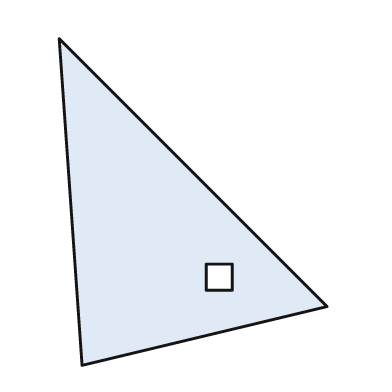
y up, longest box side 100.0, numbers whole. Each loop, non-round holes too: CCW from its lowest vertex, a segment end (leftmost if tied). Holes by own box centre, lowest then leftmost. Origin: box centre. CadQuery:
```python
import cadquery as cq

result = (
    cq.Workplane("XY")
    .moveTo(-34.0, -50.0)
    .lineTo(41.0, -32.0)
    .lineTo(-41.0, 50.0)
    .close()
    .moveTo(4.0, -27.0)
    .lineTo(12.0, -27.0)
    .lineTo(12.0, -19.0)
    .lineTo(4.0, -19.0)
    .close()
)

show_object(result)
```